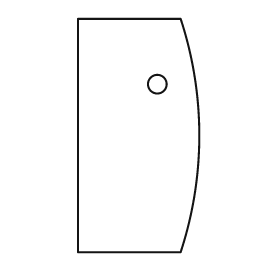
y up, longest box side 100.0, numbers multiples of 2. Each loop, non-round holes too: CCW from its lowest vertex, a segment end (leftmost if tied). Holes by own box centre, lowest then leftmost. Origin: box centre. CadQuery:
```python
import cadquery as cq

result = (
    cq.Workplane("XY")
    .moveTo(-26.0, -50.0)
    .lineTo(18.0, -50.0)
    .threePointArc((26.0, 0.0), (18.0, 50.0))
    .lineTo(-26.0, 50.0)
    .close()
    .moveTo(8.0, 22.0)
    .circle(4.0)
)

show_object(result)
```